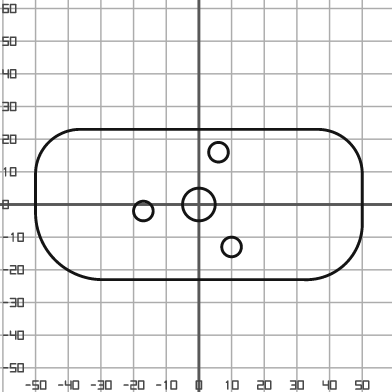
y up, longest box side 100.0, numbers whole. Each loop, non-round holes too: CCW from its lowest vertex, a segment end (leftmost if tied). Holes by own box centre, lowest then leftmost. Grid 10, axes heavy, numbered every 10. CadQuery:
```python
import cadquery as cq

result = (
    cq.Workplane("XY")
    .moveTo(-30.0, -23.0)
    .lineTo(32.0, -23.0)
    .threePointArc((45.0, -18.0), (50.0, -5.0))
    .lineTo(50.0, 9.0)
    .threePointArc((46.0, 19.0), (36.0, 23.0))
    .lineTo(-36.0, 23.0)
    .threePointArc((-46.0, 19.0), (-50.0, 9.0))
    .lineTo(-50.0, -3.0)
    .threePointArc((-44.0, -17.0), (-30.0, -23.0))
    .close()
    .moveTo(10.0, -13.0)
    .circle(3.0)
    .moveTo(-17.0, -2.0)
    .circle(3.0)
    .moveTo(0.0, 0.0)
    .circle(5.0)
    .moveTo(6.0, 16.0)
    .circle(3.0)
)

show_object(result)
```